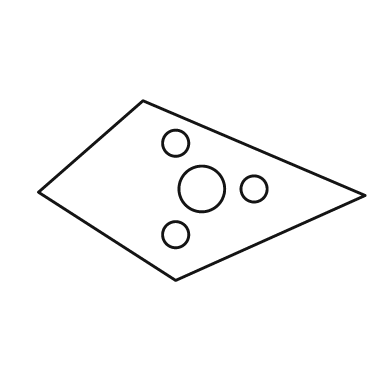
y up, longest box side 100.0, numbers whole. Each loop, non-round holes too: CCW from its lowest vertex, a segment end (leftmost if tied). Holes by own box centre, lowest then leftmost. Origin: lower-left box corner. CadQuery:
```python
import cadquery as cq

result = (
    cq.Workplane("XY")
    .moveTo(42.0, 0.0)
    .lineTo(100.0, 26.0)
    .lineTo(32.0, 55.0)
    .lineTo(0.0, 27.0)
    .close()
    .moveTo(42.0, 14.0)
    .circle(4.0)
    .moveTo(50.0, 28.0)
    .circle(7.0)
    .moveTo(66.0, 28.0)
    .circle(4.0)
    .moveTo(42.0, 42.0)
    .circle(4.0)
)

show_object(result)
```